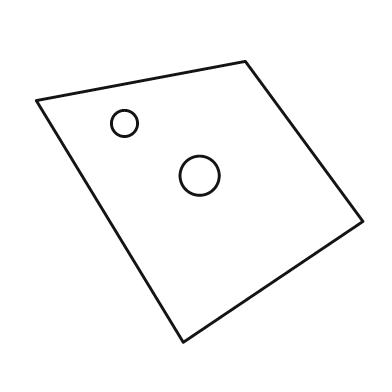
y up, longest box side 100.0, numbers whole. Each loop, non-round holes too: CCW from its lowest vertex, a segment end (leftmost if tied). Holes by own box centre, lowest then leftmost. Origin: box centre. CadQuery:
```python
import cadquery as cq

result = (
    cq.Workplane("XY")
    .moveTo(-5.0, -43.0)
    .lineTo(50.0, -6.0)
    .lineTo(14.0, 43.0)
    .lineTo(-50.0, 31.0)
    .close()
    .moveTo(0.0, 8.0)
    .circle(6.0)
    .moveTo(-23.0, 24.0)
    .circle(4.0)
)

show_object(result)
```